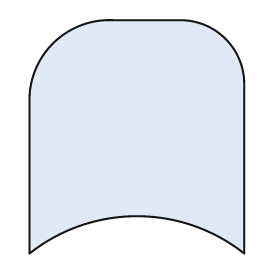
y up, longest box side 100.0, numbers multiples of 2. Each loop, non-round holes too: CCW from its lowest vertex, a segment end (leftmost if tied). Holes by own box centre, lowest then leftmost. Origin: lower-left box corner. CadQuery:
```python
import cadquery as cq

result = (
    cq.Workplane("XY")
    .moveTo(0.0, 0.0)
    .threePointArc((46.0, 16.0), (92.0, 0.0))
    .lineTo(92.0, 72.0)
    .threePointArc((84.0, 92.0), (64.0, 100.0))
    .lineTo(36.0, 100.0)
    .threePointArc((10.0, 90.0), (0.0, 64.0))
    .close()
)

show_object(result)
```